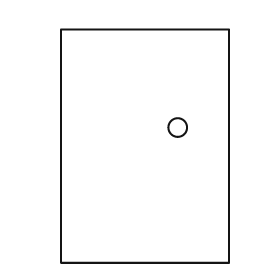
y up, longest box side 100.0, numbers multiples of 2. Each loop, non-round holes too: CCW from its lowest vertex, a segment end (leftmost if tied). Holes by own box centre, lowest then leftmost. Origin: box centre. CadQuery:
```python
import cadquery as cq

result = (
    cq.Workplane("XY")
    .moveTo(-36.0, -50.0)
    .lineTo(36.0, -50.0)
    .lineTo(36.0, 50.0)
    .lineTo(-36.0, 50.0)
    .close()
    .moveTo(14.0, 8.0)
    .circle(4.0)
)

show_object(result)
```